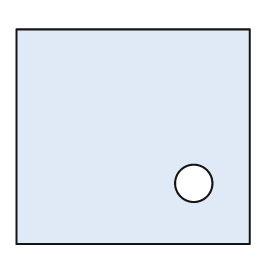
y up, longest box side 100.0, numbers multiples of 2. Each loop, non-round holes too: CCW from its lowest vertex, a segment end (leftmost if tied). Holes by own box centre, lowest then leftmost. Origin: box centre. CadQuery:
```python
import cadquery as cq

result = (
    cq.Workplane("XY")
    .moveTo(-50.0, -46.0)
    .lineTo(50.0, -46.0)
    .lineTo(50.0, 46.0)
    .lineTo(-50.0, 46.0)
    .close()
    .moveTo(26.0, -20.0)
    .circle(8.0)
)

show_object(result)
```